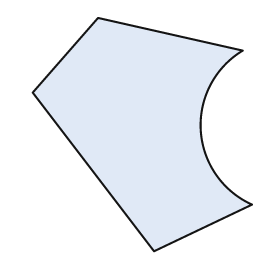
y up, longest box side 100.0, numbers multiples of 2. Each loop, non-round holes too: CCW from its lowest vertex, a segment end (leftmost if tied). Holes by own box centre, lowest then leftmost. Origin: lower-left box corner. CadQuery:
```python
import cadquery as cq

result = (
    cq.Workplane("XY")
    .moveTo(52.0, 0.0)
    .lineTo(94.0, 20.0)
    .threePointArc((72.0, 52.0), (90.0, 86.0))
    .lineTo(28.0, 100.0)
    .lineTo(0.0, 68.0)
    .close()
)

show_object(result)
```